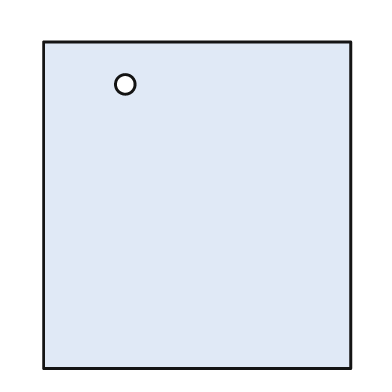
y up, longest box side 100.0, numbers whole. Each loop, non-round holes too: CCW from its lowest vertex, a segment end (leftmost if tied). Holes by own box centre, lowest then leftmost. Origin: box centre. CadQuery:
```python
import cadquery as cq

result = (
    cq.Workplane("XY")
    .moveTo(-47.0, -50.0)
    .lineTo(47.0, -50.0)
    .lineTo(47.0, 50.0)
    .lineTo(-47.0, 50.0)
    .close()
    .moveTo(-22.0, 37.0)
    .circle(3.0)
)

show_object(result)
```